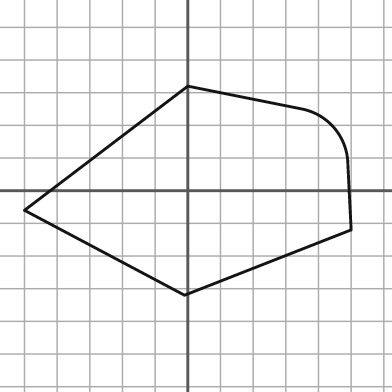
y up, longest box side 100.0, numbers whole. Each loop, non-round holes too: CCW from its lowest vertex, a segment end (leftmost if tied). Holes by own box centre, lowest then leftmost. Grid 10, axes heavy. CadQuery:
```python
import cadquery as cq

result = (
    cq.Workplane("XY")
    .moveTo(-1.0, -32.0)
    .lineTo(50.0, -12.0)
    .lineTo(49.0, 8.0)
    .threePointArc((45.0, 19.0), (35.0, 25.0))
    .lineTo(0.0, 32.0)
    .lineTo(-50.0, -6.0)
    .close()
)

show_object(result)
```